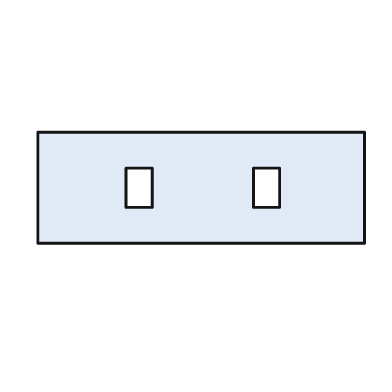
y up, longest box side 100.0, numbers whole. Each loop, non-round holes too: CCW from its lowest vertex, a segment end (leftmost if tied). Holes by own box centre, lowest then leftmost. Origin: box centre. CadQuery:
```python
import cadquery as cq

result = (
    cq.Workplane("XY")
    .moveTo(-50.0, -17.0)
    .lineTo(50.0, -17.0)
    .lineTo(50.0, 17.0)
    .lineTo(-50.0, 17.0)
    .close()
    .moveTo(-23.0, -6.0)
    .lineTo(-15.0, -6.0)
    .lineTo(-15.0, 6.0)
    .lineTo(-23.0, 6.0)
    .close()
    .moveTo(16.0, -6.0)
    .lineTo(24.0, -6.0)
    .lineTo(24.0, 6.0)
    .lineTo(16.0, 6.0)
    .close()
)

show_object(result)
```